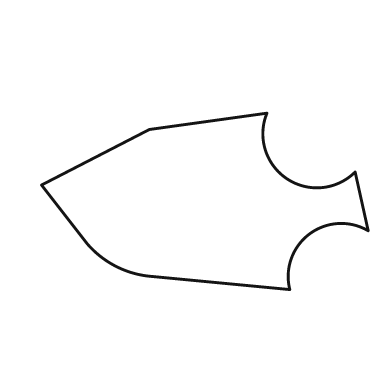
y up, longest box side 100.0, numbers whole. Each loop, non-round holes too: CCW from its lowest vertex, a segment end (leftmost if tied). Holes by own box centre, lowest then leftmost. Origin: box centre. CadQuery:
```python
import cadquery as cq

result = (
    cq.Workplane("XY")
    .moveTo(26.0, -27.0)
    .threePointArc((32.0, -10.0), (50.0, -9.0))
    .lineTo(46.0, 9.0)
    .threePointArc((25.0, 7.0), (19.0, 27.0))
    .lineTo(-17.0, 22.0)
    .lineTo(-50.0, 5.0)
    .lineTo(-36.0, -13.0)
    .threePointArc((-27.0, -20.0), (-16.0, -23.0))
    .close()
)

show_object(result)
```